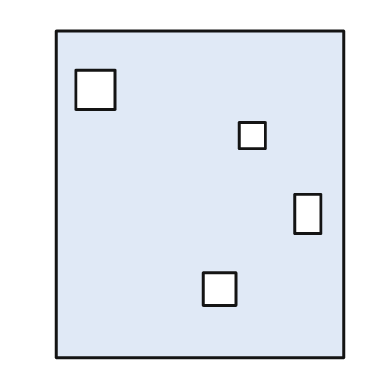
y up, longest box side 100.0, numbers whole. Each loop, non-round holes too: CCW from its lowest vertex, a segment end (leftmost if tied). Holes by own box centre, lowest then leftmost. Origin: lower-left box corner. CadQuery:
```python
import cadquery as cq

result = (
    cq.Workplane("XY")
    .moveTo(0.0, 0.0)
    .lineTo(88.0, 0.0)
    .lineTo(88.0, 100.0)
    .lineTo(0.0, 100.0)
    .close()
    .moveTo(45.0, 16.0)
    .lineTo(55.0, 16.0)
    .lineTo(55.0, 26.0)
    .lineTo(45.0, 26.0)
    .close()
    .moveTo(73.0, 38.0)
    .lineTo(81.0, 38.0)
    .lineTo(81.0, 50.0)
    .lineTo(73.0, 50.0)
    .close()
    .moveTo(56.0, 64.0)
    .lineTo(64.0, 64.0)
    .lineTo(64.0, 72.0)
    .lineTo(56.0, 72.0)
    .close()
    .moveTo(6.0, 76.0)
    .lineTo(18.0, 76.0)
    .lineTo(18.0, 88.0)
    .lineTo(6.0, 88.0)
    .close()
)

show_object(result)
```